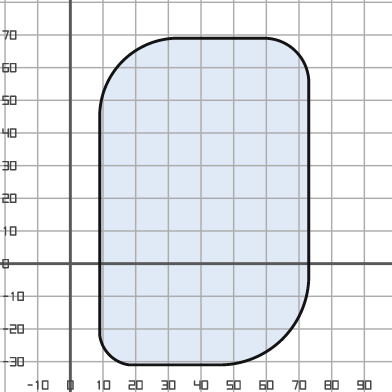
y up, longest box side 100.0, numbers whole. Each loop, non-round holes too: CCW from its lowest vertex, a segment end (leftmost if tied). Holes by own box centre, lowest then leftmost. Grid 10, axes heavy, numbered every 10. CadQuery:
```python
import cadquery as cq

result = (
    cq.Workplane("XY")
    .moveTo(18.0, -31.0)
    .lineTo(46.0, -31.0)
    .threePointArc((65.0, -23.0), (73.0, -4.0))
    .lineTo(73.0, 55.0)
    .threePointArc((69.0, 65.0), (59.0, 69.0))
    .lineTo(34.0, 69.0)
    .threePointArc((16.0, 62.0), (9.0, 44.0))
    .lineTo(9.0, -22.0)
    .threePointArc((12.0, -28.0), (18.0, -31.0))
    .close()
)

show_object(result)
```